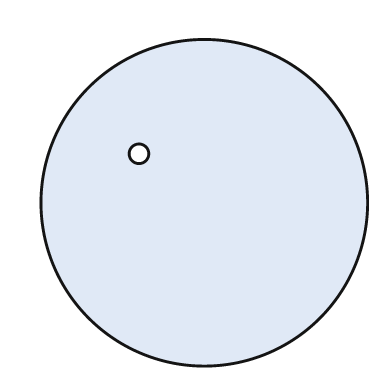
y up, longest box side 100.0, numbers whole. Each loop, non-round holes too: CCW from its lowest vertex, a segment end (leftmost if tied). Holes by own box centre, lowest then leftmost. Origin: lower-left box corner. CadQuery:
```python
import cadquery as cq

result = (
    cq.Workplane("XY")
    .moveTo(50.0, 50.0)
    .circle(50.0)
    .moveTo(30.0, 65.0)
    .circle(3.0)
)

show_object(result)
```